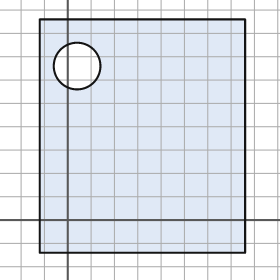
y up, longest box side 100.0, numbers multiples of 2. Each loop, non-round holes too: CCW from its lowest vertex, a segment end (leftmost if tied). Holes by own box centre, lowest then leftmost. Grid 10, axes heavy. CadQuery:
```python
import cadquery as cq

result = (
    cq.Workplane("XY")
    .moveTo(-12.0, -14.0)
    .lineTo(76.0, -14.0)
    .lineTo(76.0, 86.0)
    .lineTo(-12.0, 86.0)
    .close()
    .moveTo(4.0, 66.0)
    .circle(10.0)
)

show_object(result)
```